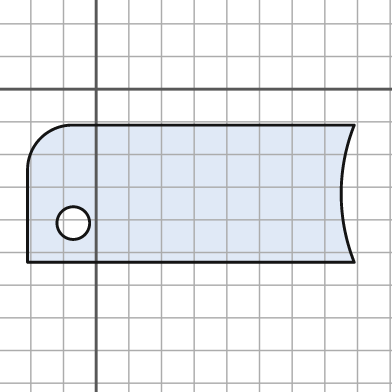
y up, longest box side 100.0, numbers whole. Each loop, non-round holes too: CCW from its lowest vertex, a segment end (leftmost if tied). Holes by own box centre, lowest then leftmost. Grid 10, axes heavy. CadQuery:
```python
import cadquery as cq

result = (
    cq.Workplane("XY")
    .moveTo(-21.0, -53.0)
    .lineTo(79.0, -53.0)
    .threePointArc((75.0, -32.0), (79.0, -11.0))
    .lineTo(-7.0, -11.0)
    .threePointArc((-17.0, -15.0), (-21.0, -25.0))
    .close()
    .moveTo(-7.0, -41.0)
    .circle(5.0)
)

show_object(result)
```